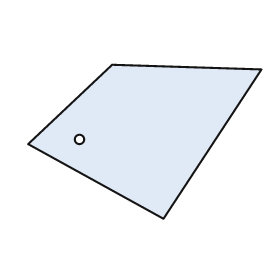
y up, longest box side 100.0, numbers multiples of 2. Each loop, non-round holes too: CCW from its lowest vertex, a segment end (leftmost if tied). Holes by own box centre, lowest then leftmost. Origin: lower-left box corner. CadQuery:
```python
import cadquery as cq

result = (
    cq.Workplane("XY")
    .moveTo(58.0, 0.0)
    .lineTo(100.0, 64.0)
    .lineTo(36.0, 66.0)
    .lineTo(0.0, 32.0)
    .close()
    .moveTo(22.0, 34.0)
    .circle(2.0)
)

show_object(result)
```